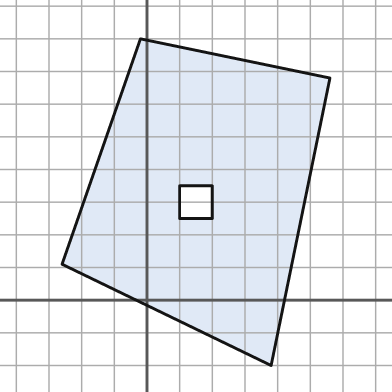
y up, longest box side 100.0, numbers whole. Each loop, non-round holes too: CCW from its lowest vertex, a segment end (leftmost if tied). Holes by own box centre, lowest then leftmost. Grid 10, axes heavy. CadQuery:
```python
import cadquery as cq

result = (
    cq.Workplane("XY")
    .moveTo(38.0, -20.0)
    .lineTo(56.0, 68.0)
    .lineTo(-2.0, 80.0)
    .lineTo(-26.0, 11.0)
    .close()
    .moveTo(10.0, 25.0)
    .lineTo(20.0, 25.0)
    .lineTo(20.0, 35.0)
    .lineTo(10.0, 35.0)
    .close()
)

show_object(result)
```